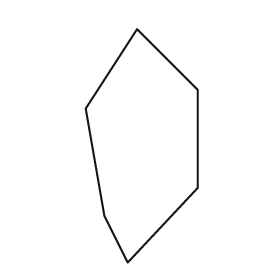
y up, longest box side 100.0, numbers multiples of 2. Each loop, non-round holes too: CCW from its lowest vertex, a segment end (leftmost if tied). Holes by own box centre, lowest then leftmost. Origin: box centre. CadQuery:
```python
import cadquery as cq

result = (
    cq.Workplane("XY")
    .moveTo(-6.0, -50.0)
    .lineTo(24.0, -18.0)
    .lineTo(24.0, 24.0)
    .lineTo(-2.0, 50.0)
    .lineTo(-24.0, 16.0)
    .lineTo(-16.0, -30.0)
    .close()
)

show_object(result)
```